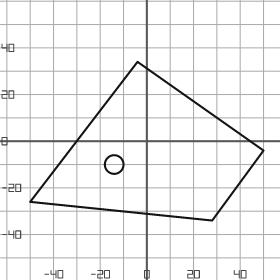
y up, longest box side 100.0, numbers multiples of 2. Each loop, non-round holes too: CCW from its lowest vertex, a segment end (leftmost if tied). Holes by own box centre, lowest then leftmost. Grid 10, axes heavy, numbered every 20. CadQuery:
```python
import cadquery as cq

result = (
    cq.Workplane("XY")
    .moveTo(28.0, -34.0)
    .lineTo(50.0, -4.0)
    .lineTo(-4.0, 34.0)
    .lineTo(-50.0, -26.0)
    .close()
    .moveTo(-14.0, -10.0)
    .circle(4.0)
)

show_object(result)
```